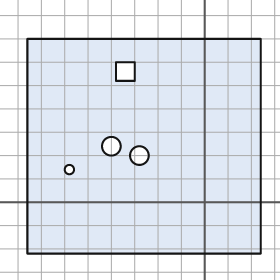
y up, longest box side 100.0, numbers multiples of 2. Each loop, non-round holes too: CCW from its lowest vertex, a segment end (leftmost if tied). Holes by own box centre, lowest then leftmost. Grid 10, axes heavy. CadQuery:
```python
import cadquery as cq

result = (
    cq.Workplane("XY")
    .moveTo(-76.0, -22.0)
    .lineTo(24.0, -22.0)
    .lineTo(24.0, 70.0)
    .lineTo(-76.0, 70.0)
    .close()
    .moveTo(-58.0, 14.0)
    .circle(2.0)
    .moveTo(-28.0, 20.0)
    .circle(4.0)
    .moveTo(-40.0, 24.0)
    .circle(4.0)
    .moveTo(-38.0, 52.0)
    .lineTo(-30.0, 52.0)
    .lineTo(-30.0, 60.0)
    .lineTo(-38.0, 60.0)
    .close()
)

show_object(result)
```